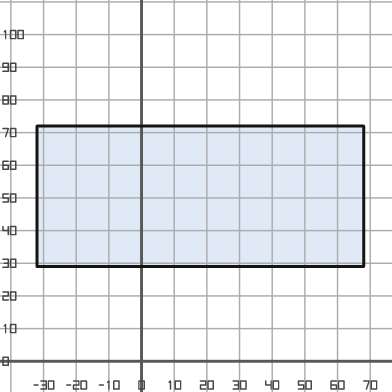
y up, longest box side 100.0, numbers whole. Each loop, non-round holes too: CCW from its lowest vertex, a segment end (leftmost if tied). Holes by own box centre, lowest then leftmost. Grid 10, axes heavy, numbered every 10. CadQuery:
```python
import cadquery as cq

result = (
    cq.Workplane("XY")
    .moveTo(-32.0, 29.0)
    .lineTo(68.0, 29.0)
    .lineTo(68.0, 72.0)
    .lineTo(-32.0, 72.0)
    .close()
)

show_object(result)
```